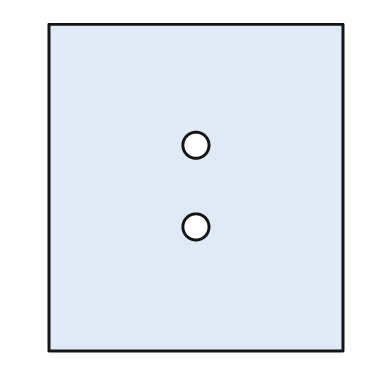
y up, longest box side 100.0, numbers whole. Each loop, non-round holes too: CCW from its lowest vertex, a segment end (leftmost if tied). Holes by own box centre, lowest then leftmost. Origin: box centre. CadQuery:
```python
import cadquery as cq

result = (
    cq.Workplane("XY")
    .moveTo(-45.0, -50.0)
    .lineTo(45.0, -50.0)
    .lineTo(45.0, 50.0)
    .lineTo(-45.0, 50.0)
    .close()
    .moveTo(0.0, -12.0)
    .circle(4.0)
    .moveTo(0.0, 13.0)
    .circle(4.0)
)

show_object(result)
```